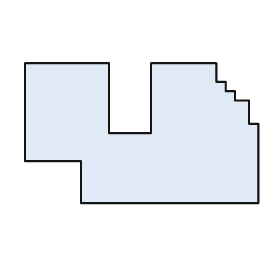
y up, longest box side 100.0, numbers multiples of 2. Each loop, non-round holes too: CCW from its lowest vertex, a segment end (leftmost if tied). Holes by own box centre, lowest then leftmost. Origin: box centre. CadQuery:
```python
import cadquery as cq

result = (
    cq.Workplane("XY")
    .moveTo(-26.0, -30.0)
    .lineTo(50.0, -30.0)
    .lineTo(50.0, 4.0)
    .lineTo(46.0, 4.0)
    .lineTo(46.0, 14.0)
    .lineTo(40.0, 14.0)
    .lineTo(40.0, 18.0)
    .lineTo(36.0, 18.0)
    .lineTo(36.0, 22.0)
    .lineTo(32.0, 22.0)
    .lineTo(32.0, 30.0)
    .lineTo(4.0, 30.0)
    .lineTo(4.0, 0.0)
    .lineTo(-14.0, 0.0)
    .lineTo(-14.0, 30.0)
    .lineTo(-50.0, 30.0)
    .lineTo(-50.0, -12.0)
    .lineTo(-26.0, -12.0)
    .close()
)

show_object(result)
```